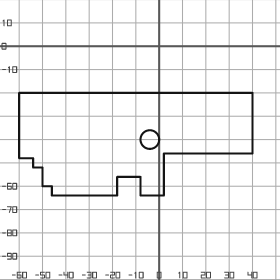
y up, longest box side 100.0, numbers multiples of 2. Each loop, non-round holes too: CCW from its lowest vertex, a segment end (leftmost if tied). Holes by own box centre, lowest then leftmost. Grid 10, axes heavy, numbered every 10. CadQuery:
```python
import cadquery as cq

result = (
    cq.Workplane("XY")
    .moveTo(-46.0, -64.0)
    .lineTo(-18.0, -64.0)
    .lineTo(-18.0, -56.0)
    .lineTo(-8.0, -56.0)
    .lineTo(-8.0, -64.0)
    .lineTo(2.0, -64.0)
    .lineTo(2.0, -46.0)
    .lineTo(40.0, -46.0)
    .lineTo(40.0, -20.0)
    .lineTo(-60.0, -20.0)
    .lineTo(-60.0, -48.0)
    .lineTo(-54.0, -48.0)
    .lineTo(-54.0, -52.0)
    .lineTo(-50.0, -52.0)
    .lineTo(-50.0, -60.0)
    .lineTo(-46.0, -60.0)
    .close()
    .moveTo(-4.0, -40.0)
    .circle(4.0)
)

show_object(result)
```